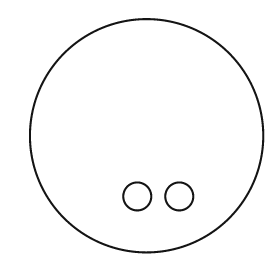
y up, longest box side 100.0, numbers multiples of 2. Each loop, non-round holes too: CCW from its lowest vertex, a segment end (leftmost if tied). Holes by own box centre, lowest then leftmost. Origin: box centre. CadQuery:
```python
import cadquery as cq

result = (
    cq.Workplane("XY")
    .moveTo(0.0, 0.0)
    .circle(50.0)
    .moveTo(-4.0, -26.0)
    .circle(6.0)
    .moveTo(14.0, -26.0)
    .circle(6.0)
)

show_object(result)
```